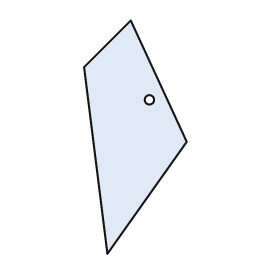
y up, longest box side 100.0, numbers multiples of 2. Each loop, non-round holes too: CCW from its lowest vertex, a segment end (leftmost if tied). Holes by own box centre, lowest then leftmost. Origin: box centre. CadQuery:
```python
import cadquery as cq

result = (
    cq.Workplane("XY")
    .moveTo(-12.0, -50.0)
    .lineTo(22.0, -2.0)
    .lineTo(-2.0, 50.0)
    .lineTo(-22.0, 30.0)
    .close()
    .moveTo(6.0, 16.0)
    .circle(2.0)
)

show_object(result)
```